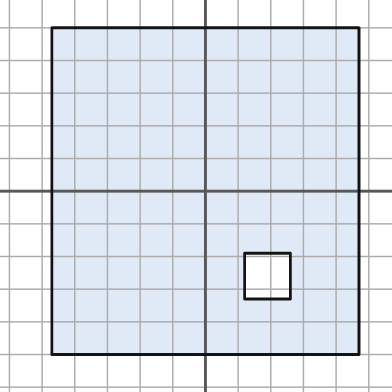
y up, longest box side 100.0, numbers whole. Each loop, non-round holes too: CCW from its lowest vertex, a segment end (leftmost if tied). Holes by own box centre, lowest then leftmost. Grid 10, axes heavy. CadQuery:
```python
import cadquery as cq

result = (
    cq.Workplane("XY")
    .moveTo(-47.0, -50.0)
    .lineTo(47.0, -50.0)
    .lineTo(47.0, 50.0)
    .lineTo(-47.0, 50.0)
    .close()
    .moveTo(12.0, -33.0)
    .lineTo(26.0, -33.0)
    .lineTo(26.0, -19.0)
    .lineTo(12.0, -19.0)
    .close()
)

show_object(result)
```